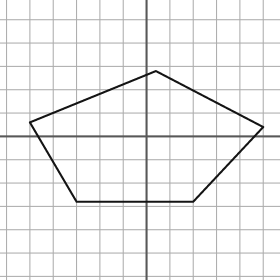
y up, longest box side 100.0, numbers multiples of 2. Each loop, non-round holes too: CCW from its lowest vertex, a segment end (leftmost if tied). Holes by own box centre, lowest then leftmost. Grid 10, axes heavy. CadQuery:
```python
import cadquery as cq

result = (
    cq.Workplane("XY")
    .moveTo(-30.0, -28.0)
    .lineTo(20.0, -28.0)
    .lineTo(50.0, 4.0)
    .lineTo(4.0, 28.0)
    .lineTo(-50.0, 6.0)
    .close()
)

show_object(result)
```